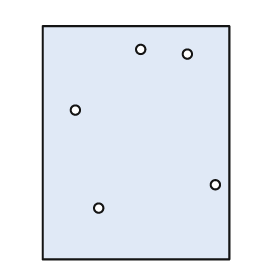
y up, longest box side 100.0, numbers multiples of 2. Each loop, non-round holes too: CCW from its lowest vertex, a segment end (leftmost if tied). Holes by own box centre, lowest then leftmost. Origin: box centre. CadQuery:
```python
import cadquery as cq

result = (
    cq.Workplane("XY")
    .moveTo(-40.0, -50.0)
    .lineTo(40.0, -50.0)
    .lineTo(40.0, 50.0)
    .lineTo(-40.0, 50.0)
    .close()
    .moveTo(-16.0, -28.0)
    .circle(2.0)
    .moveTo(34.0, -18.0)
    .circle(2.0)
    .moveTo(-26.0, 14.0)
    .circle(2.0)
    .moveTo(22.0, 38.0)
    .circle(2.0)
    .moveTo(2.0, 40.0)
    .circle(2.0)
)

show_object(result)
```